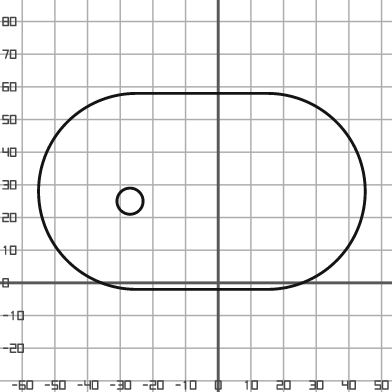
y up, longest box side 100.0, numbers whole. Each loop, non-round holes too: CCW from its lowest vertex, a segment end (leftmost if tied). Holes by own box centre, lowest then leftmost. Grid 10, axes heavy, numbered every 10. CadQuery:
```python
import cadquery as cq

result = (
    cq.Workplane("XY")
    .moveTo(-25.0, -2.0)
    .lineTo(15.0, -2.0)
    .threePointArc((45.0, 28.0), (15.0, 58.0))
    .lineTo(-25.0, 58.0)
    .threePointArc((-55.0, 28.0), (-25.0, -2.0))
    .close()
    .moveTo(-27.0, 25.0)
    .circle(4.0)
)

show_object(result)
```